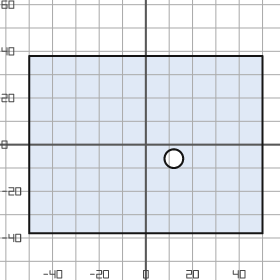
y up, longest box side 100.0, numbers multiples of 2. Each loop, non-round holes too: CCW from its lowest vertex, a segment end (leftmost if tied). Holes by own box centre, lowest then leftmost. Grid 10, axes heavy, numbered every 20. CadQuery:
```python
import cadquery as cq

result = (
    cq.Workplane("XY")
    .moveTo(-50.0, -38.0)
    .lineTo(50.0, -38.0)
    .lineTo(50.0, 38.0)
    .lineTo(-50.0, 38.0)
    .close()
    .moveTo(12.0, -6.0)
    .circle(4.0)
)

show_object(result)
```